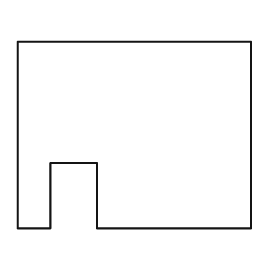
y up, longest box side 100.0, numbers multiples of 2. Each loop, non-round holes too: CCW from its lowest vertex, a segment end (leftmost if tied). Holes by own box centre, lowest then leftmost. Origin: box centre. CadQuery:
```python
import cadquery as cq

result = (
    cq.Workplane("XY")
    .moveTo(-50.0, -40.0)
    .lineTo(-36.0, -40.0)
    .lineTo(-36.0, -12.0)
    .lineTo(-16.0, -12.0)
    .lineTo(-16.0, -40.0)
    .lineTo(50.0, -40.0)
    .lineTo(50.0, 40.0)
    .lineTo(-50.0, 40.0)
    .close()
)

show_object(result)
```